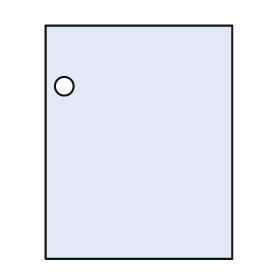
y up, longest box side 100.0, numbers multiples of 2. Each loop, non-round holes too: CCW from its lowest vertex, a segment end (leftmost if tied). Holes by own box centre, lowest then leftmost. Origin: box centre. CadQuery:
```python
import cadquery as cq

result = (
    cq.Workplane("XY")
    .moveTo(-40.0, -50.0)
    .lineTo(40.0, -50.0)
    .lineTo(40.0, 50.0)
    .lineTo(-40.0, 50.0)
    .close()
    .moveTo(-32.0, 24.0)
    .circle(4.0)
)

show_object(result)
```